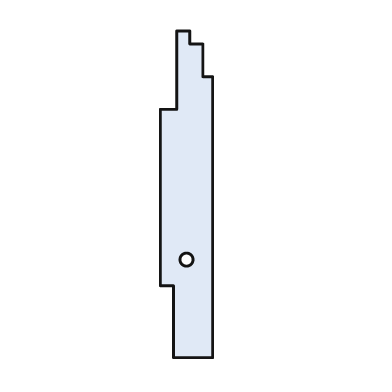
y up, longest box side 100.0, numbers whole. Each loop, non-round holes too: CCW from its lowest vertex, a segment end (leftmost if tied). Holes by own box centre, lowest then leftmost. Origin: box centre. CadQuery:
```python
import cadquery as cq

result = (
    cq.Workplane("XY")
    .moveTo(-4.0, -50.0)
    .lineTo(8.0, -50.0)
    .lineTo(8.0, 36.0)
    .lineTo(5.0, 36.0)
    .lineTo(5.0, 46.0)
    .lineTo(1.0, 46.0)
    .lineTo(1.0, 50.0)
    .lineTo(-3.0, 50.0)
    .lineTo(-3.0, 26.0)
    .lineTo(-8.0, 26.0)
    .lineTo(-8.0, -28.0)
    .lineTo(-4.0, -28.0)
    .close()
    .moveTo(0.0, -20.0)
    .circle(2.0)
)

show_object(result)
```